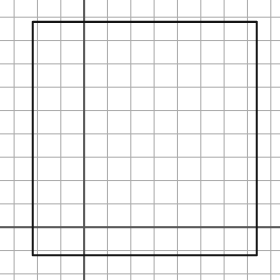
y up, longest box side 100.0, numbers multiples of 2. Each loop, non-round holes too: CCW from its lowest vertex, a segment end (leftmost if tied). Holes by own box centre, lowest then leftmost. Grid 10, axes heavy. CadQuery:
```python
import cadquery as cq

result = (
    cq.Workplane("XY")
    .moveTo(-22.0, -12.0)
    .lineTo(74.0, -12.0)
    .lineTo(74.0, 88.0)
    .lineTo(-22.0, 88.0)
    .close()
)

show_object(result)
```